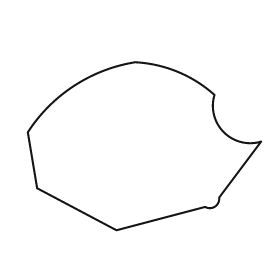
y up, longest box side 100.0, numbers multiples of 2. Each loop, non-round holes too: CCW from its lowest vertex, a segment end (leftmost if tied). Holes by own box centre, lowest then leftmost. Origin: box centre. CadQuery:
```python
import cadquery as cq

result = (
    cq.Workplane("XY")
    .moveTo(-12.0, -36.0)
    .lineTo(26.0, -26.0)
    .threePointArc((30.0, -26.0), (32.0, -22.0))
    .lineTo(50.0, 2.0)
    .threePointArc((34.0, 6.0), (30.0, 22.0))
    .threePointArc((14.0, 32.0), (-4.0, 36.0))
    .threePointArc((-30.0, 26.0), (-50.0, 6.0))
    .lineTo(-46.0, -18.0)
    .close()
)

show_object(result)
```